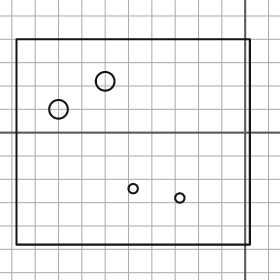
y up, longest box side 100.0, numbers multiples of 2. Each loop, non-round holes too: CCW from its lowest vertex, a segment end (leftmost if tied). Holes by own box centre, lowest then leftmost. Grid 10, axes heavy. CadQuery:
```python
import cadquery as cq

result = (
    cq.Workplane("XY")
    .moveTo(-98.0, -48.0)
    .lineTo(2.0, -48.0)
    .lineTo(2.0, 40.0)
    .lineTo(-98.0, 40.0)
    .close()
    .moveTo(-28.0, -28.0)
    .circle(2.0)
    .moveTo(-48.0, -24.0)
    .circle(2.0)
    .moveTo(-80.0, 10.0)
    .circle(4.0)
    .moveTo(-60.0, 22.0)
    .circle(4.0)
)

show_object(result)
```